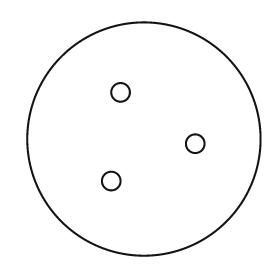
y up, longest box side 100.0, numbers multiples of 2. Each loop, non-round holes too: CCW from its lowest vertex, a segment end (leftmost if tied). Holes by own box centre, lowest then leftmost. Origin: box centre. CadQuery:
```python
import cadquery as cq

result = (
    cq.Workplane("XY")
    .moveTo(0.0, 0.0)
    .circle(50.0)
    .moveTo(-14.0, -18.0)
    .circle(4.0)
    .moveTo(22.0, -2.0)
    .circle(4.0)
    .moveTo(-10.0, 20.0)
    .circle(4.0)
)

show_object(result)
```